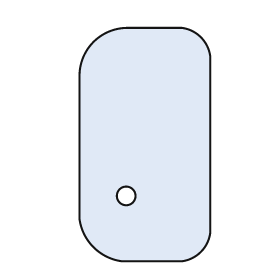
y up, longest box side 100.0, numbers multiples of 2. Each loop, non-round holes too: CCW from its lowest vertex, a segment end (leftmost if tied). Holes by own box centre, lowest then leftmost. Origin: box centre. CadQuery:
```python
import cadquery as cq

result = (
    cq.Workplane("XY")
    .moveTo(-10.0, -50.0)
    .lineTo(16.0, -50.0)
    .threePointArc((24.0, -46.0), (28.0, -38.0))
    .lineTo(28.0, 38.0)
    .threePointArc((24.0, 46.0), (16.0, 50.0))
    .lineTo(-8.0, 50.0)
    .threePointArc((-22.0, 44.0), (-28.0, 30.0))
    .lineTo(-28.0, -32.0)
    .threePointArc((-22.0, -44.0), (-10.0, -50.0))
    .close()
    .moveTo(-8.0, -22.0)
    .circle(4.0)
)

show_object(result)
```